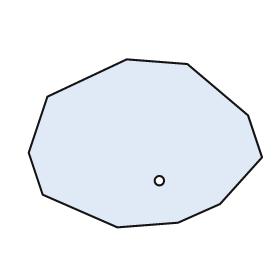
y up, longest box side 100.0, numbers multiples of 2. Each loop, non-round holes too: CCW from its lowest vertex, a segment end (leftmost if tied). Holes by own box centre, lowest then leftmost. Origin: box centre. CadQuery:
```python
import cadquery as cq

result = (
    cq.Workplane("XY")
    .moveTo(-12.0, -36.0)
    .lineTo(14.0, -34.0)
    .lineTo(32.0, -26.0)
    .lineTo(50.0, -6.0)
    .lineTo(44.0, 12.0)
    .lineTo(18.0, 34.0)
    .lineTo(-8.0, 36.0)
    .lineTo(-42.0, 20.0)
    .lineTo(-50.0, -4.0)
    .lineTo(-44.0, -22.0)
    .close()
    .moveTo(6.0, -16.0)
    .circle(2.0)
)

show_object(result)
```